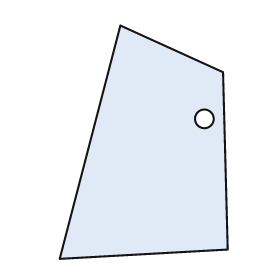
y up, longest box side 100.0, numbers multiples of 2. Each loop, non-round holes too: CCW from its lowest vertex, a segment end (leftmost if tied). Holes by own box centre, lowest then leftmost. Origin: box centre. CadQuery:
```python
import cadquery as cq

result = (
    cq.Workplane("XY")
    .moveTo(-36.0, -50.0)
    .lineTo(36.0, -46.0)
    .lineTo(34.0, 30.0)
    .lineTo(-10.0, 50.0)
    .close()
    .moveTo(26.0, 10.0)
    .circle(4.0)
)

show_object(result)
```